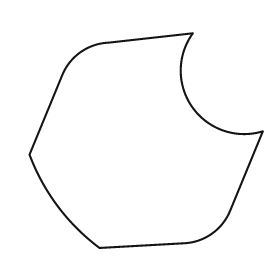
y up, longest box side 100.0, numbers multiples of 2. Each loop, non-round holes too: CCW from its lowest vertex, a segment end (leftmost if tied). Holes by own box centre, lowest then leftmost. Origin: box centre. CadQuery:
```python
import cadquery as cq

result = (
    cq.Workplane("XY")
    .moveTo(-20.0, -46.0)
    .lineTo(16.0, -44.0)
    .threePointArc((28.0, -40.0), (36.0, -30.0))
    .lineTo(50.0, 4.0)
    .threePointArc((20.0, 14.0), (20.0, 46.0))
    .lineTo(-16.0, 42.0)
    .threePointArc((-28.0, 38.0), (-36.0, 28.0))
    .lineTo(-50.0, -6.0)
    .threePointArc((-38.0, -28.0), (-20.0, -46.0))
    .close()
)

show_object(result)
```